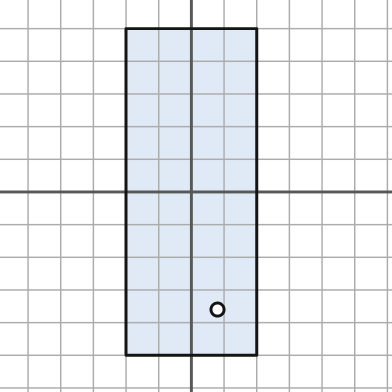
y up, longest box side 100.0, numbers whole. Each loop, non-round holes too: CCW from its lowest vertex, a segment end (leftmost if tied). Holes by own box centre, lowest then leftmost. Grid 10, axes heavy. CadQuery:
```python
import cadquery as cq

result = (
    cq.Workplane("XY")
    .moveTo(-20.0, -50.0)
    .lineTo(20.0, -50.0)
    .lineTo(20.0, 50.0)
    .lineTo(-20.0, 50.0)
    .close()
    .moveTo(8.0, -36.0)
    .circle(2.0)
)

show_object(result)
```